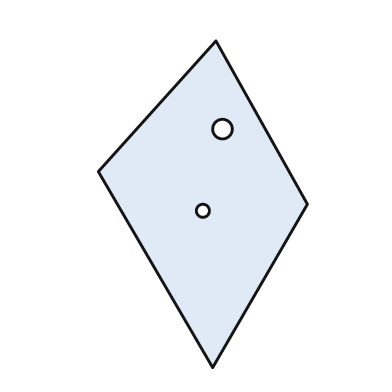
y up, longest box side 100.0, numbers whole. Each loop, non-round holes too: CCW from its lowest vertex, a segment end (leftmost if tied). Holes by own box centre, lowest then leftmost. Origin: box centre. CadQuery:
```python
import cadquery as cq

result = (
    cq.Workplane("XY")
    .moveTo(3.0, -50.0)
    .lineTo(32.0, 0.0)
    .lineTo(4.0, 50.0)
    .lineTo(-32.0, 10.0)
    .close()
    .moveTo(0.0, -2.0)
    .circle(2.0)
    .moveTo(6.0, 23.0)
    .circle(3.0)
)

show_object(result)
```